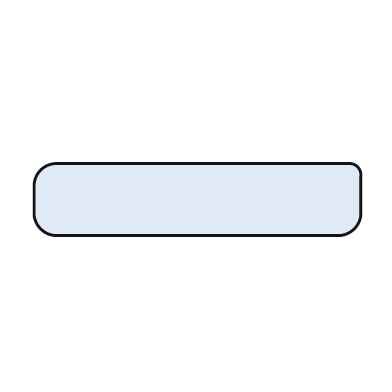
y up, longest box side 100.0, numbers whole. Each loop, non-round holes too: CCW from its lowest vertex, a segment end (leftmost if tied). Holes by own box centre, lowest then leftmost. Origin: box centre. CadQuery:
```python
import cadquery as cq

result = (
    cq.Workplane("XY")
    .moveTo(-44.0, -11.0)
    .lineTo(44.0, -11.0)
    .threePointArc((48.0, -9.0), (50.0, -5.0))
    .lineTo(50.0, 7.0)
    .threePointArc((49.0, 10.0), (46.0, 11.0))
    .lineTo(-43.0, 11.0)
    .threePointArc((-48.0, 9.0), (-50.0, 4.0))
    .lineTo(-50.0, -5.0)
    .threePointArc((-48.0, -9.0), (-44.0, -11.0))
    .close()
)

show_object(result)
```